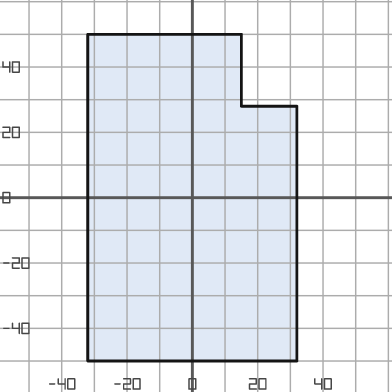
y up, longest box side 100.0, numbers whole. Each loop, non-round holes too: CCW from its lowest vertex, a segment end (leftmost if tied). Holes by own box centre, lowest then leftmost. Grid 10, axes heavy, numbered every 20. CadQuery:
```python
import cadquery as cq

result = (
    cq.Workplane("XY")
    .moveTo(-32.0, -50.0)
    .lineTo(32.0, -50.0)
    .lineTo(32.0, 28.0)
    .lineTo(15.0, 28.0)
    .lineTo(15.0, 50.0)
    .lineTo(-32.0, 50.0)
    .close()
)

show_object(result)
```